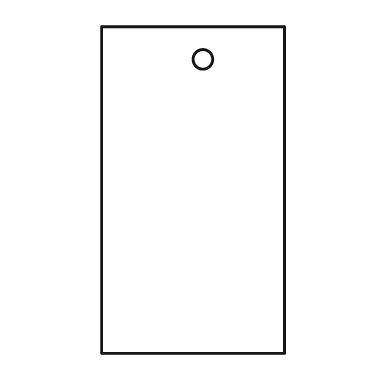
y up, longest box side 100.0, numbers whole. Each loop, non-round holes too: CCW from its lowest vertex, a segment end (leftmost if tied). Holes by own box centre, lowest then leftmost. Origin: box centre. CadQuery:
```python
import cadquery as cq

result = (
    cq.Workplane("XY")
    .moveTo(-28.0, -50.0)
    .lineTo(28.0, -50.0)
    .lineTo(28.0, 50.0)
    .lineTo(-28.0, 50.0)
    .close()
    .moveTo(3.0, 40.0)
    .circle(3.0)
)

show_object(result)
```